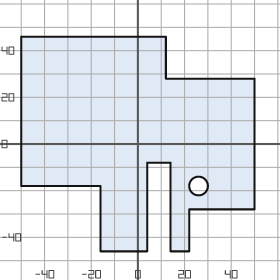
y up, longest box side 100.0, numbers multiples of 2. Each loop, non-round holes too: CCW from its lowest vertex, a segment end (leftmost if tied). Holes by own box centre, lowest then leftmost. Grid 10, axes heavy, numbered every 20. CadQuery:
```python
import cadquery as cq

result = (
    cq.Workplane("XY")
    .moveTo(-16.0, -46.0)
    .lineTo(4.0, -46.0)
    .lineTo(4.0, -8.0)
    .lineTo(14.0, -8.0)
    .lineTo(14.0, -46.0)
    .lineTo(22.0, -46.0)
    .lineTo(22.0, -28.0)
    .lineTo(50.0, -28.0)
    .lineTo(50.0, 28.0)
    .lineTo(12.0, 28.0)
    .lineTo(12.0, 46.0)
    .lineTo(-50.0, 46.0)
    .lineTo(-50.0, -18.0)
    .lineTo(-16.0, -18.0)
    .close()
    .moveTo(26.0, -18.0)
    .circle(4.0)
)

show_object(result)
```